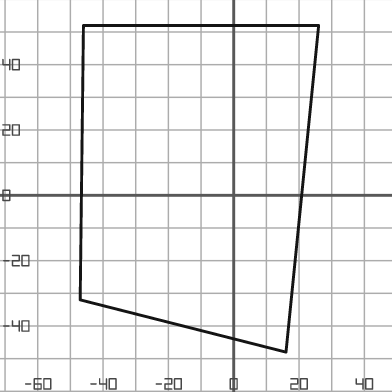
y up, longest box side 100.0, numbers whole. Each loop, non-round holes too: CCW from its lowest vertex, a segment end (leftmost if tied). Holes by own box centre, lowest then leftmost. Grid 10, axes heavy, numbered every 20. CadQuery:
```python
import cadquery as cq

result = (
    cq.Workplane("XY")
    .moveTo(16.0, -48.0)
    .lineTo(26.0, 52.0)
    .lineTo(-46.0, 52.0)
    .lineTo(-47.0, -32.0)
    .close()
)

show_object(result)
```